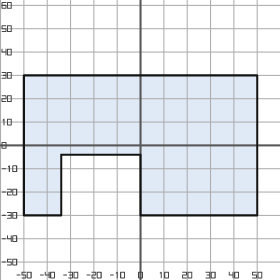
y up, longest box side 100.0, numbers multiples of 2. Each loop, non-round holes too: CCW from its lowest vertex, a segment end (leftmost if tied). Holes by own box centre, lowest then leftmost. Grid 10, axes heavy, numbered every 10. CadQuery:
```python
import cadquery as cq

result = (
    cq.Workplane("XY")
    .moveTo(-50.0, -30.0)
    .lineTo(-34.0, -30.0)
    .lineTo(-34.0, -4.0)
    .lineTo(0.0, -4.0)
    .lineTo(0.0, -30.0)
    .lineTo(50.0, -30.0)
    .lineTo(50.0, 30.0)
    .lineTo(-50.0, 30.0)
    .close()
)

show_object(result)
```